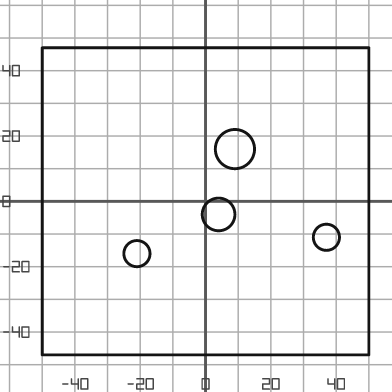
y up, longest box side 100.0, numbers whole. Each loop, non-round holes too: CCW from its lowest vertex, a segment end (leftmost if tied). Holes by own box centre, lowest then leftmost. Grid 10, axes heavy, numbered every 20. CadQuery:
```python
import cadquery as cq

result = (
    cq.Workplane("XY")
    .moveTo(-50.0, -47.0)
    .lineTo(50.0, -47.0)
    .lineTo(50.0, 47.0)
    .lineTo(-50.0, 47.0)
    .close()
    .moveTo(-21.0, -16.0)
    .circle(4.0)
    .moveTo(37.0, -11.0)
    .circle(4.0)
    .moveTo(4.0, -4.0)
    .circle(5.0)
    .moveTo(9.0, 16.0)
    .circle(6.0)
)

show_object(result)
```